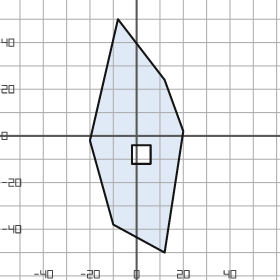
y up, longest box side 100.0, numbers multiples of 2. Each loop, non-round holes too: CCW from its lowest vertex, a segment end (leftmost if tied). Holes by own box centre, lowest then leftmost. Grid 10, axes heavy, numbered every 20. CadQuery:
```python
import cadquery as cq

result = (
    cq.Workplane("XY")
    .moveTo(12.0, -50.0)
    .lineTo(20.0, 2.0)
    .lineTo(12.0, 24.0)
    .lineTo(-8.0, 50.0)
    .lineTo(-20.0, -2.0)
    .lineTo(-10.0, -38.0)
    .close()
    .moveTo(-2.0, -12.0)
    .lineTo(6.0, -12.0)
    .lineTo(6.0, -4.0)
    .lineTo(-2.0, -4.0)
    .close()
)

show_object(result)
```